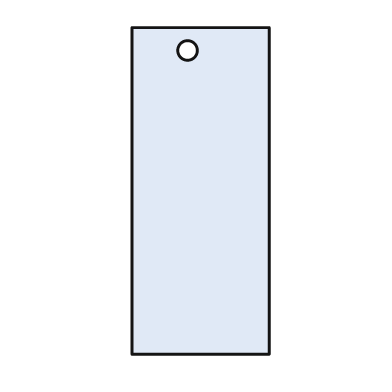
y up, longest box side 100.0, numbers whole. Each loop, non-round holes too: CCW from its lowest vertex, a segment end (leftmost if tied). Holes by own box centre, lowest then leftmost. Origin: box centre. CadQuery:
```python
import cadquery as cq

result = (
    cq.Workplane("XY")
    .moveTo(-21.0, -50.0)
    .lineTo(21.0, -50.0)
    .lineTo(21.0, 50.0)
    .lineTo(-21.0, 50.0)
    .close()
    .moveTo(-4.0, 43.0)
    .circle(3.0)
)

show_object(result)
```